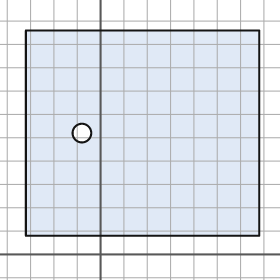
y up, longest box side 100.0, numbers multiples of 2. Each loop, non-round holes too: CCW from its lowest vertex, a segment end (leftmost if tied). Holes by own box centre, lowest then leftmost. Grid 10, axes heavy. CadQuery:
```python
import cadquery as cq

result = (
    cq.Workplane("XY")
    .moveTo(-32.0, 8.0)
    .lineTo(68.0, 8.0)
    .lineTo(68.0, 96.0)
    .lineTo(-32.0, 96.0)
    .close()
    .moveTo(-8.0, 52.0)
    .circle(4.0)
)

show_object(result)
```